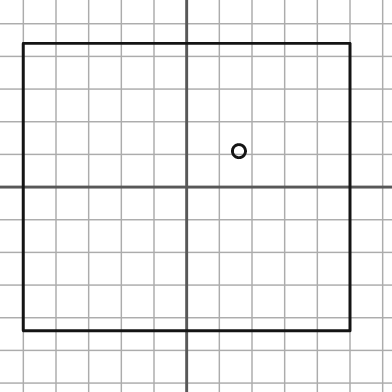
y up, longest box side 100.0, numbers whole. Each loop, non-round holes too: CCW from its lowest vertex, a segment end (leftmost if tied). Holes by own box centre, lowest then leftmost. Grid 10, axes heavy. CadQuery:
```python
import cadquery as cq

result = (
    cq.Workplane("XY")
    .moveTo(-50.0, -44.0)
    .lineTo(50.0, -44.0)
    .lineTo(50.0, 44.0)
    .lineTo(-50.0, 44.0)
    .close()
    .moveTo(16.0, 11.0)
    .circle(2.0)
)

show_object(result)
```